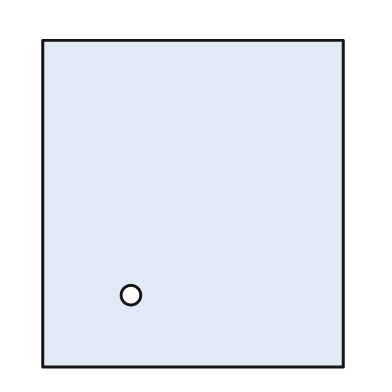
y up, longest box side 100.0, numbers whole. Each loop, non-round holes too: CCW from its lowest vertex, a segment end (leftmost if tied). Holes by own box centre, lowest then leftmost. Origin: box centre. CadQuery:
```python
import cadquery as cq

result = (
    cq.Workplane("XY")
    .moveTo(-46.0, -50.0)
    .lineTo(46.0, -50.0)
    .lineTo(46.0, 50.0)
    .lineTo(-46.0, 50.0)
    .close()
    .moveTo(-19.0, -28.0)
    .circle(3.0)
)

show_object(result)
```